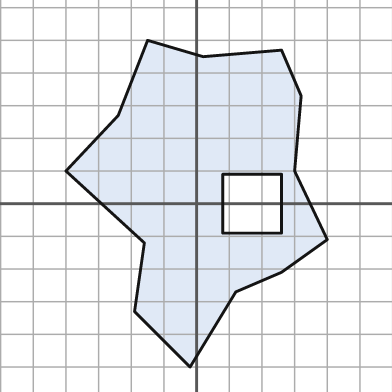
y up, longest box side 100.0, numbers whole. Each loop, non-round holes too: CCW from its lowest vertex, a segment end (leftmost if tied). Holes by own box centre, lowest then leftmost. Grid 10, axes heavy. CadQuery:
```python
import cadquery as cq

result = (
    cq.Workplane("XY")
    .moveTo(-2.0, -50.0)
    .lineTo(12.0, -27.0)
    .lineTo(26.0, -21.0)
    .lineTo(40.0, -11.0)
    .lineTo(30.0, 10.0)
    .lineTo(32.0, 33.0)
    .lineTo(26.0, 47.0)
    .lineTo(2.0, 45.0)
    .lineTo(-15.0, 50.0)
    .lineTo(-24.0, 27.0)
    .lineTo(-40.0, 10.0)
    .lineTo(-16.0, -12.0)
    .lineTo(-19.0, -33.0)
    .close()
    .moveTo(8.0, -9.0)
    .lineTo(26.0, -9.0)
    .lineTo(26.0, 9.0)
    .lineTo(8.0, 9.0)
    .close()
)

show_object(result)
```